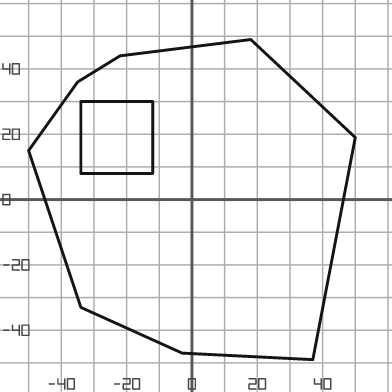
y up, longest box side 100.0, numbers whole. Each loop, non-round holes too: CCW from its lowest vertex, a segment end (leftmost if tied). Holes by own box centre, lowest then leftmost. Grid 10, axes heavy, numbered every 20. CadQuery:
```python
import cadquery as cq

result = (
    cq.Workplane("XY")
    .moveTo(37.0, -49.0)
    .lineTo(50.0, 19.0)
    .lineTo(18.0, 49.0)
    .lineTo(-22.0, 44.0)
    .lineTo(-35.0, 36.0)
    .lineTo(-50.0, 15.0)
    .lineTo(-34.0, -33.0)
    .lineTo(-3.0, -47.0)
    .close()
    .moveTo(-34.0, 8.0)
    .lineTo(-12.0, 8.0)
    .lineTo(-12.0, 30.0)
    .lineTo(-34.0, 30.0)
    .close()
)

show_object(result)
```